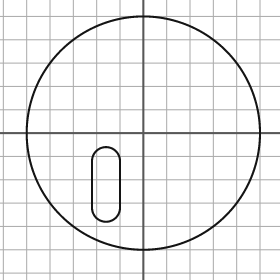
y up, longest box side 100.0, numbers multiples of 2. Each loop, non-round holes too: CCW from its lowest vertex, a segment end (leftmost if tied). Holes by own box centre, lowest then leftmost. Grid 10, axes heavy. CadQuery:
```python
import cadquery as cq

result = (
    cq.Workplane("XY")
    .moveTo(0.0, 0.0)
    .circle(50.0)
    .moveTo(-22.0, -32.0)
    .threePointArc((-16.0, -38.0), (-10.0, -32.0))
    .lineTo(-10.0, -12.0)
    .threePointArc((-16.0, -6.0), (-22.0, -12.0))
    .close()
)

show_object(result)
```